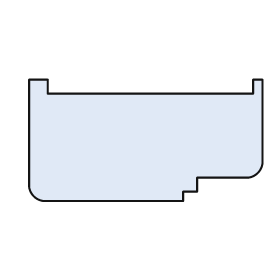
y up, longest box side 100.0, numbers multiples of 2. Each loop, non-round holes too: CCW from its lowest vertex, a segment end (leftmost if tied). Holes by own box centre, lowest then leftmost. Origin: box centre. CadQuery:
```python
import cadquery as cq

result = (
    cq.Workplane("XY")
    .moveTo(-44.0, -26.0)
    .lineTo(16.0, -26.0)
    .lineTo(16.0, -22.0)
    .lineTo(22.0, -22.0)
    .lineTo(22.0, -16.0)
    .lineTo(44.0, -16.0)
    .threePointArc((48.0, -14.0), (50.0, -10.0))
    .lineTo(50.0, 26.0)
    .lineTo(46.0, 26.0)
    .lineTo(46.0, 20.0)
    .lineTo(-42.0, 20.0)
    .lineTo(-42.0, 26.0)
    .lineTo(-50.0, 26.0)
    .lineTo(-50.0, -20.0)
    .threePointArc((-48.0, -24.0), (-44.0, -26.0))
    .close()
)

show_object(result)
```